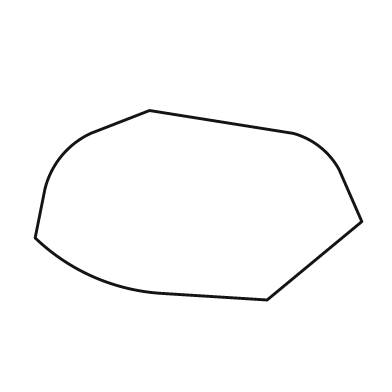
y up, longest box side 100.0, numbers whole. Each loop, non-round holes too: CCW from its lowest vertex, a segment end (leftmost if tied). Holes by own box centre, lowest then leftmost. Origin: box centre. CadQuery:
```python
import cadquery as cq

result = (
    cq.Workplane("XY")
    .moveTo(21.0, -29.0)
    .lineTo(50.0, -5.0)
    .lineTo(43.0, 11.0)
    .threePointArc((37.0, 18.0), (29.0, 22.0))
    .lineTo(-15.0, 29.0)
    .lineTo(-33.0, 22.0)
    .threePointArc((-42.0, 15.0), (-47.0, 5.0))
    .lineTo(-50.0, -10.0)
    .threePointArc((-32.0, -22.0), (-11.0, -27.0))
    .close()
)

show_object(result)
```